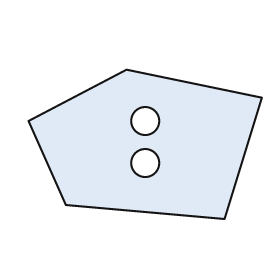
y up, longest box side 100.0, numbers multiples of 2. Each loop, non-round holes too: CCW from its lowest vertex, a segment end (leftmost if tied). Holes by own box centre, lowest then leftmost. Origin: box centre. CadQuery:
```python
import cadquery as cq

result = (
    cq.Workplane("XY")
    .moveTo(34.0, -32.0)
    .lineTo(50.0, 20.0)
    .lineTo(-8.0, 32.0)
    .lineTo(-50.0, 10.0)
    .lineTo(-34.0, -26.0)
    .close()
    .moveTo(0.0, -8.0)
    .circle(6.0)
    .moveTo(0.0, 10.0)
    .circle(6.0)
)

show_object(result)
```